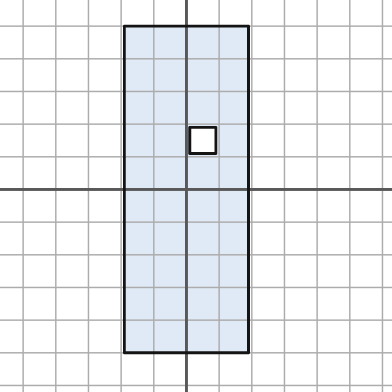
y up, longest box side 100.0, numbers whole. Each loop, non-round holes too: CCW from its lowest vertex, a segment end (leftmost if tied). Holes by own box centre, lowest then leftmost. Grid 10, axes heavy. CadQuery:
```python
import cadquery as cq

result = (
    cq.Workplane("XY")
    .moveTo(-19.0, -50.0)
    .lineTo(19.0, -50.0)
    .lineTo(19.0, 50.0)
    .lineTo(-19.0, 50.0)
    .close()
    .moveTo(1.0, 11.0)
    .lineTo(9.0, 11.0)
    .lineTo(9.0, 19.0)
    .lineTo(1.0, 19.0)
    .close()
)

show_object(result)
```